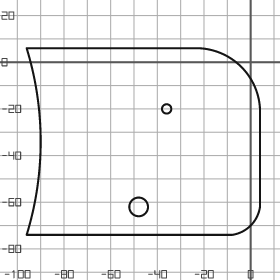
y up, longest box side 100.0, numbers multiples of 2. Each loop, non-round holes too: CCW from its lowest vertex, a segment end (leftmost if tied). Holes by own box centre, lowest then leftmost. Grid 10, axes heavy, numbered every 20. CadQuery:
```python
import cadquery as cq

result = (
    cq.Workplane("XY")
    .moveTo(-96.0, -74.0)
    .lineTo(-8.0, -74.0)
    .threePointArc((0.0, -70.0), (4.0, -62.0))
    .lineTo(4.0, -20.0)
    .threePointArc((-4.0, -2.0), (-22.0, 6.0))
    .lineTo(-96.0, 6.0)
    .threePointArc((-90.0, -34.0), (-96.0, -74.0))
    .close()
    .moveTo(-48.0, -62.0)
    .circle(4.0)
    .moveTo(-36.0, -20.0)
    .circle(2.0)
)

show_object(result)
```